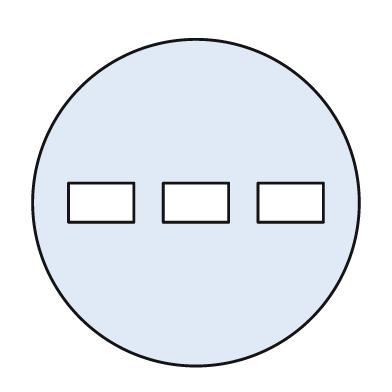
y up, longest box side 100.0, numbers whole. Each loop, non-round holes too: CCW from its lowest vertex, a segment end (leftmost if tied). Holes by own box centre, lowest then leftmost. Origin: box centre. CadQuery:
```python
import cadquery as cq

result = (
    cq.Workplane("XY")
    .moveTo(0.0, 0.0)
    .circle(50.0)
    .moveTo(-39.0, -6.0)
    .lineTo(-19.0, -6.0)
    .lineTo(-19.0, 6.0)
    .lineTo(-39.0, 6.0)
    .close()
    .moveTo(-10.0, -6.0)
    .lineTo(10.0, -6.0)
    .lineTo(10.0, 6.0)
    .lineTo(-10.0, 6.0)
    .close()
    .moveTo(19.0, -6.0)
    .lineTo(39.0, -6.0)
    .lineTo(39.0, 6.0)
    .lineTo(19.0, 6.0)
    .close()
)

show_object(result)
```